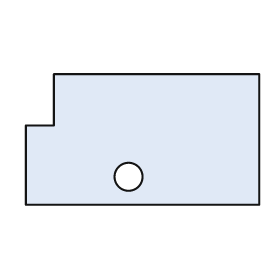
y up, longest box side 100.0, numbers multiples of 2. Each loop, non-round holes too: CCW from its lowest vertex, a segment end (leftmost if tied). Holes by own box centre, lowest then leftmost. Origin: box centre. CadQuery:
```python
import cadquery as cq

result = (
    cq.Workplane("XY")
    .moveTo(-50.0, -28.0)
    .lineTo(50.0, -28.0)
    .lineTo(50.0, 28.0)
    .lineTo(-38.0, 28.0)
    .lineTo(-38.0, 6.0)
    .lineTo(-50.0, 6.0)
    .close()
    .moveTo(-6.0, -16.0)
    .circle(6.0)
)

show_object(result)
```